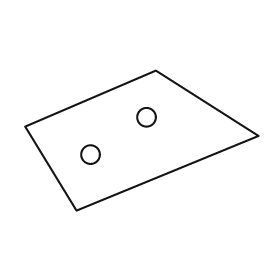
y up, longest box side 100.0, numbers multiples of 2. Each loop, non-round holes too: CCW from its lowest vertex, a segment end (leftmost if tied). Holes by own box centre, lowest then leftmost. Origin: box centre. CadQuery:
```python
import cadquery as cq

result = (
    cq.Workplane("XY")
    .moveTo(-28.0, -30.0)
    .lineTo(50.0, 2.0)
    .lineTo(6.0, 30.0)
    .lineTo(-50.0, 6.0)
    .close()
    .moveTo(-22.0, -6.0)
    .circle(4.0)
    .moveTo(2.0, 10.0)
    .circle(4.0)
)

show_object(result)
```